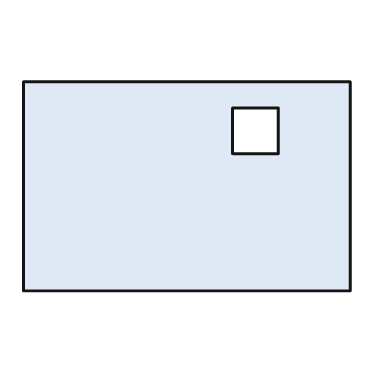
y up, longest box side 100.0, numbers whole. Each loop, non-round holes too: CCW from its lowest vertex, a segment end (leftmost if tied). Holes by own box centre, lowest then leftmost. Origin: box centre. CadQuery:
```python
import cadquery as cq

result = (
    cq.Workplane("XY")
    .moveTo(-50.0, -32.0)
    .lineTo(50.0, -32.0)
    .lineTo(50.0, 32.0)
    .lineTo(-50.0, 32.0)
    .close()
    .moveTo(14.0, 10.0)
    .lineTo(28.0, 10.0)
    .lineTo(28.0, 24.0)
    .lineTo(14.0, 24.0)
    .close()
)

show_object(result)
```